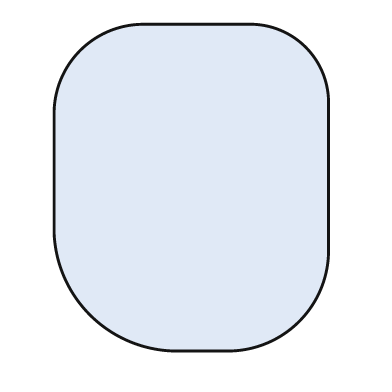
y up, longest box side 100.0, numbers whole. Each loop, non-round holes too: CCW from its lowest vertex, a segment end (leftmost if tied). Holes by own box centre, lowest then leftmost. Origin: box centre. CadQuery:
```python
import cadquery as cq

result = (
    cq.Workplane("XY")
    .moveTo(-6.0, -50.0)
    .lineTo(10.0, -50.0)
    .threePointArc((33.0, -41.0), (42.0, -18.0))
    .lineTo(42.0, 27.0)
    .threePointArc((35.0, 43.0), (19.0, 50.0))
    .lineTo(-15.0, 50.0)
    .threePointArc((-34.0, 42.0), (-42.0, 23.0))
    .lineTo(-42.0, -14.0)
    .threePointArc((-31.0, -39.0), (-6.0, -50.0))
    .close()
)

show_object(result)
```